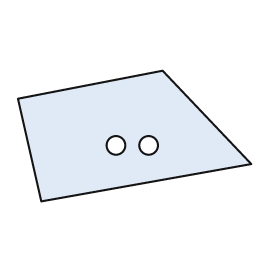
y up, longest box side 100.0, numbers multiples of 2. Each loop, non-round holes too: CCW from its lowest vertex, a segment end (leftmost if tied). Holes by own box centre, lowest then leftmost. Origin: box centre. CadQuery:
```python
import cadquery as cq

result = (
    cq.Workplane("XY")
    .moveTo(-40.0, -28.0)
    .lineTo(50.0, -12.0)
    .lineTo(12.0, 28.0)
    .lineTo(-50.0, 16.0)
    .close()
    .moveTo(-8.0, -4.0)
    .circle(4.0)
    .moveTo(6.0, -4.0)
    .circle(4.0)
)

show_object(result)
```